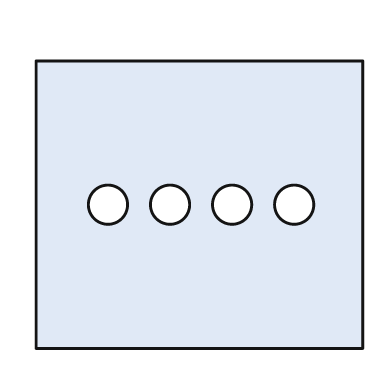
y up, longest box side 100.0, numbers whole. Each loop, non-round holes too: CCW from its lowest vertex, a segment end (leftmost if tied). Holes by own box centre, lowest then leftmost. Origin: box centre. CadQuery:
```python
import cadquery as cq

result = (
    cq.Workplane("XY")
    .moveTo(-50.0, -44.0)
    .lineTo(50.0, -44.0)
    .lineTo(50.0, 44.0)
    .lineTo(-50.0, 44.0)
    .close()
    .moveTo(-28.0, 0.0)
    .circle(6.0)
    .moveTo(-9.0, 0.0)
    .circle(6.0)
    .moveTo(10.0, 0.0)
    .circle(6.0)
    .moveTo(29.0, 0.0)
    .circle(6.0)
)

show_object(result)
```